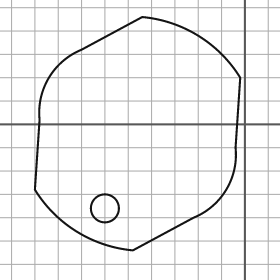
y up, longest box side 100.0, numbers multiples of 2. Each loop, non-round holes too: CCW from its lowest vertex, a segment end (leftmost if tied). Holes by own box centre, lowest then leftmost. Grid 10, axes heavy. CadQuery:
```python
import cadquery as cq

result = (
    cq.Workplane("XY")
    .moveTo(-48.0, -54.0)
    .lineTo(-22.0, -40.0)
    .threePointArc((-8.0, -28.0), (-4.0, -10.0))
    .lineTo(-2.0, 20.0)
    .threePointArc((-20.0, 38.0), (-44.0, 46.0))
    .lineTo(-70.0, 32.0)
    .threePointArc((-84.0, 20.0), (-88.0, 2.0))
    .lineTo(-90.0, -28.0)
    .threePointArc((-72.0, -46.0), (-48.0, -54.0))
    .close()
    .moveTo(-60.0, -36.0)
    .circle(6.0)
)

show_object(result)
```